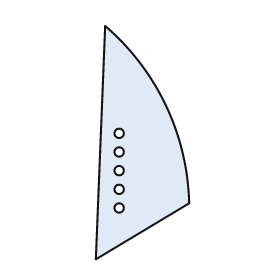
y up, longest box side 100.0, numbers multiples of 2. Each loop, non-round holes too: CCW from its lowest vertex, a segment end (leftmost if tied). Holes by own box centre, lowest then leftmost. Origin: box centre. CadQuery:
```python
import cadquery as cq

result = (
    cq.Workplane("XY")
    .moveTo(-20.0, -50.0)
    .lineTo(20.0, -26.0)
    .threePointArc((10.0, 16.0), (-16.0, 50.0))
    .close()
    .moveTo(-10.0, -28.0)
    .circle(2.0)
    .moveTo(-10.0, -20.0)
    .circle(2.0)
    .moveTo(-10.0, -12.0)
    .circle(2.0)
    .moveTo(-10.0, -4.0)
    .circle(2.0)
    .moveTo(-10.0, 4.0)
    .circle(2.0)
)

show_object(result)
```